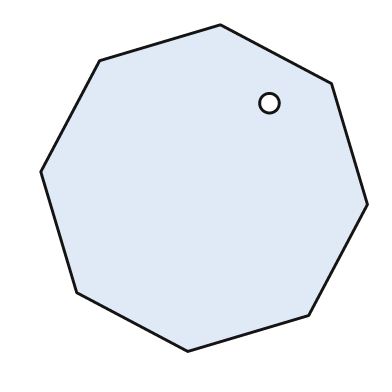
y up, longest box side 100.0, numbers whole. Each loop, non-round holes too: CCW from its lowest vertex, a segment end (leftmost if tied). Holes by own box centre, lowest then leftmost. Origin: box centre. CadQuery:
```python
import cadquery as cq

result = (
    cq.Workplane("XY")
    .moveTo(-5.0, -50.0)
    .lineTo(32.0, -39.0)
    .lineTo(50.0, -5.0)
    .lineTo(39.0, 32.0)
    .lineTo(5.0, 50.0)
    .lineTo(-32.0, 39.0)
    .lineTo(-50.0, 5.0)
    .lineTo(-39.0, -32.0)
    .close()
    .moveTo(20.0, 26.0)
    .circle(3.0)
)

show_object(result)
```